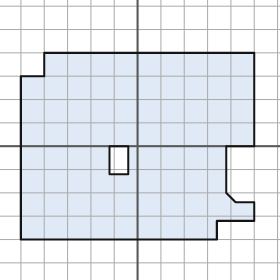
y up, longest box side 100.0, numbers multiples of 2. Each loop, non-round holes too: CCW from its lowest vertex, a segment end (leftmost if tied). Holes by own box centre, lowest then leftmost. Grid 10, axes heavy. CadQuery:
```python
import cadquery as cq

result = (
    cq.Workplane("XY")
    .moveTo(-50.0, -40.0)
    .lineTo(34.0, -40.0)
    .lineTo(34.0, -32.0)
    .lineTo(50.0, -32.0)
    .lineTo(50.0, -24.0)
    .lineTo(42.0, -24.0)
    .lineTo(38.0, -20.0)
    .lineTo(38.0, 0.0)
    .lineTo(50.0, 0.0)
    .lineTo(50.0, 40.0)
    .lineTo(-40.0, 40.0)
    .lineTo(-40.0, 30.0)
    .lineTo(-50.0, 30.0)
    .close()
    .moveTo(-12.0, -12.0)
    .lineTo(-4.0, -12.0)
    .lineTo(-4.0, 0.0)
    .lineTo(-12.0, 0.0)
    .close()
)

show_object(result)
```